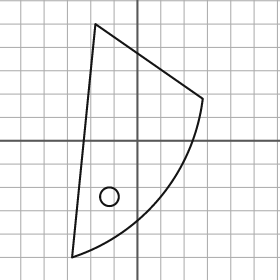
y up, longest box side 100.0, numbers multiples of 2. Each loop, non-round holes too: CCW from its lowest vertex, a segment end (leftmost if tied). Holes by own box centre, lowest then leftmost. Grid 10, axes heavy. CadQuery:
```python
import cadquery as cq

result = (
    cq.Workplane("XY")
    .moveTo(-28.0, -50.0)
    .threePointArc((10.0, -24.0), (28.0, 18.0))
    .lineTo(-18.0, 50.0)
    .close()
    .moveTo(-12.0, -24.0)
    .circle(4.0)
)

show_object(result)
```